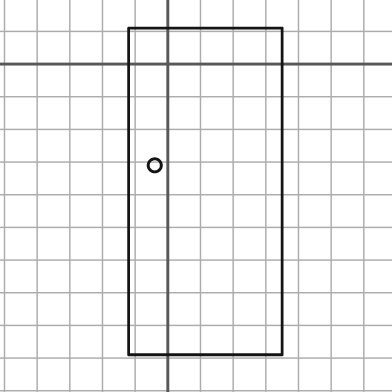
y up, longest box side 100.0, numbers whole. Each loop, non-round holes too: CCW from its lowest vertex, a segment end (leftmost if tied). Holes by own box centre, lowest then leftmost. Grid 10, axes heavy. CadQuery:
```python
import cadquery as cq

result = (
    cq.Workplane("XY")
    .moveTo(-12.0, -89.0)
    .lineTo(35.0, -89.0)
    .lineTo(35.0, 11.0)
    .lineTo(-12.0, 11.0)
    .close()
    .moveTo(-4.0, -31.0)
    .circle(2.0)
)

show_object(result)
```